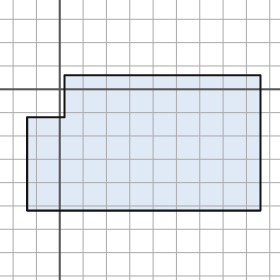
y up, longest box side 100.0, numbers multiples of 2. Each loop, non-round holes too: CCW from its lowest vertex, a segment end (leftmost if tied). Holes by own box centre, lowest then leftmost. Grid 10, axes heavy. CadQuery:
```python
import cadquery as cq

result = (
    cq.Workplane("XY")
    .moveTo(-14.0, -52.0)
    .lineTo(86.0, -52.0)
    .lineTo(86.0, 6.0)
    .lineTo(2.0, 6.0)
    .lineTo(2.0, -12.0)
    .lineTo(-14.0, -12.0)
    .close()
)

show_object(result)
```